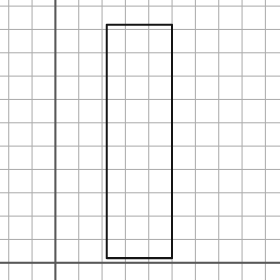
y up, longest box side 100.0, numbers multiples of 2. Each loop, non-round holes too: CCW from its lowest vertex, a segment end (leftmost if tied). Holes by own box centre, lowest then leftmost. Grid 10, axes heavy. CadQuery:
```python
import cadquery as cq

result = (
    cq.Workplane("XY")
    .moveTo(22.0, 2.0)
    .lineTo(50.0, 2.0)
    .lineTo(50.0, 102.0)
    .lineTo(22.0, 102.0)
    .close()
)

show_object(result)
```